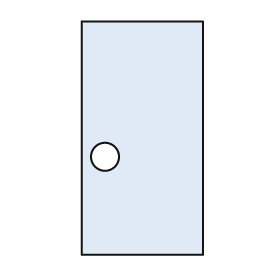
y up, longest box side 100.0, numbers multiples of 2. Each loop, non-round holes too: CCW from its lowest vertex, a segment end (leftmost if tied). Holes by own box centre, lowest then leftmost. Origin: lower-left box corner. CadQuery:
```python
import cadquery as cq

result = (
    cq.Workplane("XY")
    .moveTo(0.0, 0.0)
    .lineTo(52.0, 0.0)
    .lineTo(52.0, 100.0)
    .lineTo(0.0, 100.0)
    .close()
    .moveTo(10.0, 42.0)
    .circle(6.0)
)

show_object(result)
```